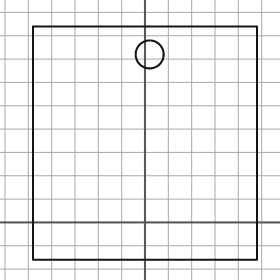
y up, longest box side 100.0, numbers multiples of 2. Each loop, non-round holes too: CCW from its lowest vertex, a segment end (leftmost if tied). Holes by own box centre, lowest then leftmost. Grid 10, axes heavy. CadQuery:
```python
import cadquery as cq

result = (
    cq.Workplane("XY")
    .moveTo(-48.0, -16.0)
    .lineTo(48.0, -16.0)
    .lineTo(48.0, 84.0)
    .lineTo(-48.0, 84.0)
    .close()
    .moveTo(2.0, 72.0)
    .circle(6.0)
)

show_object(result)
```